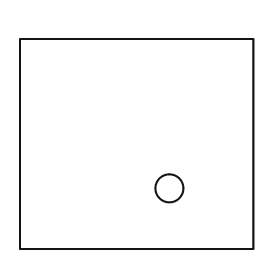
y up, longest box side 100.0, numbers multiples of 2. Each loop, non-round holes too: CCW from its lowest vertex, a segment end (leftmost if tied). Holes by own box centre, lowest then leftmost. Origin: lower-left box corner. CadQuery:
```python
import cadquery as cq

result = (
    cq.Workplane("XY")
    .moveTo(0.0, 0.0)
    .lineTo(100.0, 0.0)
    .lineTo(100.0, 90.0)
    .lineTo(0.0, 90.0)
    .close()
    .moveTo(64.0, 26.0)
    .circle(6.0)
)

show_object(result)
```